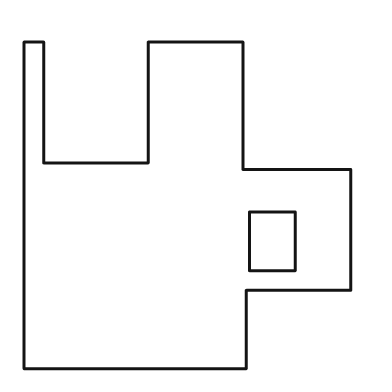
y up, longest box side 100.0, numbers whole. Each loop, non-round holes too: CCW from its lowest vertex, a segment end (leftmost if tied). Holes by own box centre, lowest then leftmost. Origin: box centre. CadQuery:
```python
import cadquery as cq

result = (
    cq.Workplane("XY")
    .moveTo(-50.0, -50.0)
    .lineTo(18.0, -50.0)
    .lineTo(18.0, -26.0)
    .lineTo(50.0, -26.0)
    .lineTo(50.0, 11.0)
    .lineTo(17.0, 11.0)
    .lineTo(17.0, 50.0)
    .lineTo(-12.0, 50.0)
    .lineTo(-12.0, 13.0)
    .lineTo(-44.0, 13.0)
    .lineTo(-44.0, 50.0)
    .lineTo(-50.0, 50.0)
    .close()
    .moveTo(19.0, -20.0)
    .lineTo(33.0, -20.0)
    .lineTo(33.0, -2.0)
    .lineTo(19.0, -2.0)
    .close()
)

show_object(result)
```